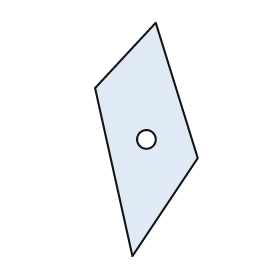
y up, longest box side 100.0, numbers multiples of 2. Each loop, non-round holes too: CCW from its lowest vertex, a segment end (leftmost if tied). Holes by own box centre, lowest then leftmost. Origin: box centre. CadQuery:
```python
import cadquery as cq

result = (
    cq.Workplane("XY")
    .moveTo(-6.0, -50.0)
    .lineTo(22.0, -8.0)
    .lineTo(4.0, 50.0)
    .lineTo(-22.0, 22.0)
    .close()
    .moveTo(0.0, 0.0)
    .circle(4.0)
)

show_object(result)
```